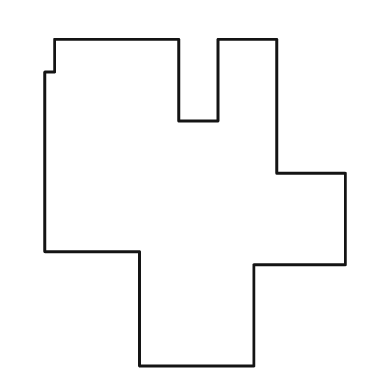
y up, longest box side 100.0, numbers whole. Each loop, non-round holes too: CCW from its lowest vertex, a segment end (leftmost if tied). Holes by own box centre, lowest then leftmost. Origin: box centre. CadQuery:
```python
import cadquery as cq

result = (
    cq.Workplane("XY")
    .moveTo(-17.0, -50.0)
    .lineTo(18.0, -50.0)
    .lineTo(18.0, -19.0)
    .lineTo(46.0, -19.0)
    .lineTo(46.0, 9.0)
    .lineTo(25.0, 9.0)
    .lineTo(25.0, 50.0)
    .lineTo(7.0, 50.0)
    .lineTo(7.0, 25.0)
    .lineTo(-5.0, 25.0)
    .lineTo(-5.0, 50.0)
    .lineTo(-43.0, 50.0)
    .lineTo(-43.0, 40.0)
    .lineTo(-46.0, 40.0)
    .lineTo(-46.0, -15.0)
    .lineTo(-17.0, -15.0)
    .close()
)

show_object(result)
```